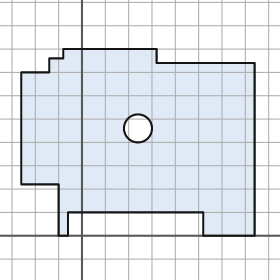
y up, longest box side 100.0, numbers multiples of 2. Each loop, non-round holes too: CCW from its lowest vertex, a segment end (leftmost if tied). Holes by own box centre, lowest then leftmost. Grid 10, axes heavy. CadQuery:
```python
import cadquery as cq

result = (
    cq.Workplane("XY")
    .moveTo(-10.0, 0.0)
    .lineTo(-6.0, 0.0)
    .lineTo(-6.0, 10.0)
    .lineTo(52.0, 10.0)
    .lineTo(52.0, 0.0)
    .lineTo(74.0, 0.0)
    .lineTo(74.0, 74.0)
    .lineTo(32.0, 74.0)
    .lineTo(32.0, 80.0)
    .lineTo(-8.0, 80.0)
    .lineTo(-8.0, 76.0)
    .lineTo(-14.0, 76.0)
    .lineTo(-14.0, 70.0)
    .lineTo(-26.0, 70.0)
    .lineTo(-26.0, 22.0)
    .lineTo(-10.0, 22.0)
    .close()
    .moveTo(24.0, 46.0)
    .circle(6.0)
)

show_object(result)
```